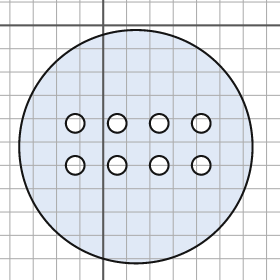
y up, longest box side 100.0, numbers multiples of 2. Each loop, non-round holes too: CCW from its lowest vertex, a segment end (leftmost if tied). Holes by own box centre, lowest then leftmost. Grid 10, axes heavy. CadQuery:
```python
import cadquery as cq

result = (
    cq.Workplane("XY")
    .moveTo(14.0, -52.0)
    .circle(50.0)
    .moveTo(-12.0, -60.0)
    .circle(4.0)
    .moveTo(6.0, -60.0)
    .circle(4.0)
    .moveTo(24.0, -60.0)
    .circle(4.0)
    .moveTo(42.0, -60.0)
    .circle(4.0)
    .moveTo(-12.0, -42.0)
    .circle(4.0)
    .moveTo(6.0, -42.0)
    .circle(4.0)
    .moveTo(24.0, -42.0)
    .circle(4.0)
    .moveTo(42.0, -42.0)
    .circle(4.0)
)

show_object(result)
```